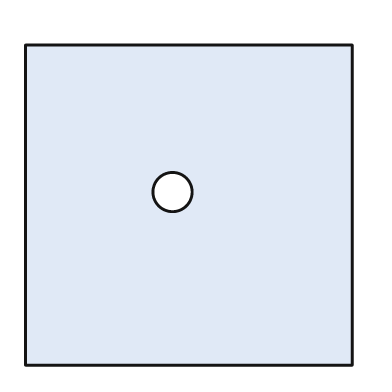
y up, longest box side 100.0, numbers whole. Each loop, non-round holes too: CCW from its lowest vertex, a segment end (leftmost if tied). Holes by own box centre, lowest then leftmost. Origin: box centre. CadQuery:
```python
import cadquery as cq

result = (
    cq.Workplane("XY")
    .moveTo(-50.0, -49.0)
    .lineTo(50.0, -49.0)
    .lineTo(50.0, 49.0)
    .lineTo(-50.0, 49.0)
    .close()
    .moveTo(-5.0, 4.0)
    .circle(6.0)
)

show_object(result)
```